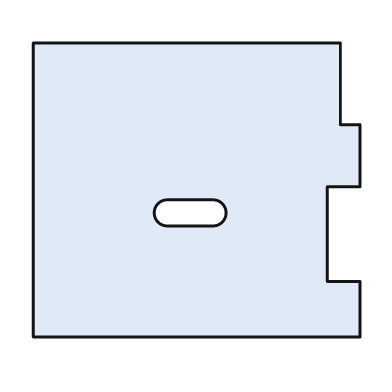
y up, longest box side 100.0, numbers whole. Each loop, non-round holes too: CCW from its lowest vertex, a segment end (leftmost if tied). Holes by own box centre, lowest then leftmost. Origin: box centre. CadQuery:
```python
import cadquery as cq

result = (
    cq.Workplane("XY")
    .moveTo(-50.0, -45.0)
    .lineTo(50.0, -45.0)
    .lineTo(50.0, -28.0)
    .lineTo(40.0, -28.0)
    .lineTo(40.0, 1.0)
    .lineTo(50.0, 1.0)
    .lineTo(50.0, 20.0)
    .lineTo(44.0, 20.0)
    .lineTo(44.0, 45.0)
    .lineTo(-50.0, 45.0)
    .close()
    .moveTo(-9.0, -11.0)
    .lineTo(5.0, -11.0)
    .threePointArc((9.0, -7.0), (5.0, -3.0))
    .lineTo(-9.0, -3.0)
    .threePointArc((-13.0, -7.0), (-9.0, -11.0))
    .close()
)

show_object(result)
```